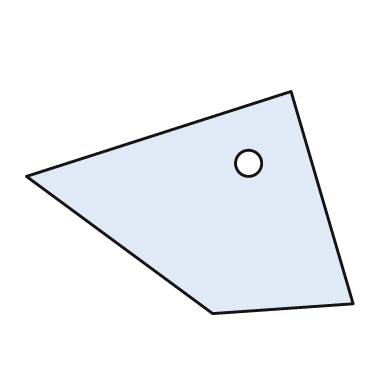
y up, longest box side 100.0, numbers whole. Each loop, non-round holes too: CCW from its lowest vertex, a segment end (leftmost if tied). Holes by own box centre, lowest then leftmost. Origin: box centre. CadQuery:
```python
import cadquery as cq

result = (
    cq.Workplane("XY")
    .moveTo(7.0, -34.0)
    .lineTo(50.0, -31.0)
    .lineTo(31.0, 34.0)
    .lineTo(-50.0, 8.0)
    .close()
    .moveTo(18.0, 12.0)
    .circle(4.0)
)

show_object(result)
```